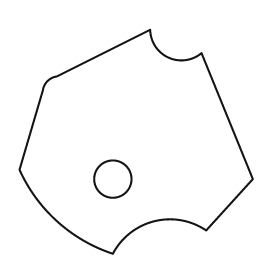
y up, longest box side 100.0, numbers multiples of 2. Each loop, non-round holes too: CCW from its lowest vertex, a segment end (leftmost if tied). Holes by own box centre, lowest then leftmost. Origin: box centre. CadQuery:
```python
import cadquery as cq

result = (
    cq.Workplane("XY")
    .moveTo(-10.0, -48.0)
    .threePointArc((8.0, -34.0), (30.0, -38.0))
    .lineTo(50.0, -16.0)
    .lineTo(28.0, 38.0)
    .threePointArc((14.0, 36.0), (6.0, 48.0))
    .lineTo(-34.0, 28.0)
    .threePointArc((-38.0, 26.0), (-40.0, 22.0))
    .lineTo(-50.0, -12.0)
    .threePointArc((-34.0, -34.0), (-10.0, -48.0))
    .close()
    .moveTo(-10.0, -16.0)
    .circle(8.0)
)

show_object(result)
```